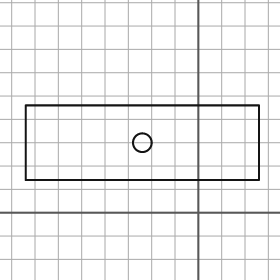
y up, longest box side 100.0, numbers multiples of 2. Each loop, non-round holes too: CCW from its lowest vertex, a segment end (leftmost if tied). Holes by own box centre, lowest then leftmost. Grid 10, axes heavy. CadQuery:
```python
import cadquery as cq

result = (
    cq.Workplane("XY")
    .moveTo(-74.0, 14.0)
    .lineTo(26.0, 14.0)
    .lineTo(26.0, 46.0)
    .lineTo(-74.0, 46.0)
    .close()
    .moveTo(-24.0, 30.0)
    .circle(4.0)
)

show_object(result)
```